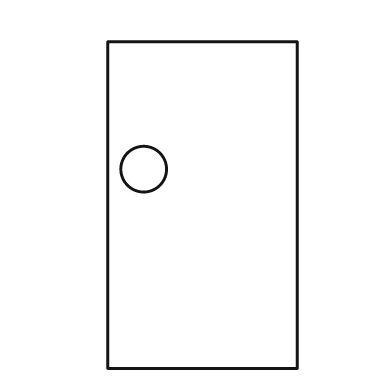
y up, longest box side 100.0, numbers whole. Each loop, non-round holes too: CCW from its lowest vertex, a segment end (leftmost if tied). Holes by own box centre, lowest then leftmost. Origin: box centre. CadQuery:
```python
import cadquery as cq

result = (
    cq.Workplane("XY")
    .moveTo(-29.0, -50.0)
    .lineTo(29.0, -50.0)
    .lineTo(29.0, 50.0)
    .lineTo(-29.0, 50.0)
    .close()
    .moveTo(-18.0, 11.0)
    .circle(7.0)
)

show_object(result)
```